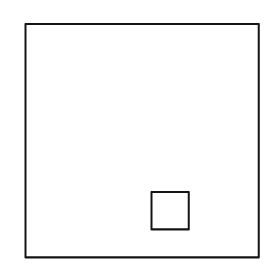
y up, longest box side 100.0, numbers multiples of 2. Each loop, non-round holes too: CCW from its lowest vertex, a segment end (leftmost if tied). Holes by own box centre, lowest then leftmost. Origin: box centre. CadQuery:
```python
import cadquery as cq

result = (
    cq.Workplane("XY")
    .moveTo(-50.0, -50.0)
    .lineTo(50.0, -50.0)
    .lineTo(50.0, 50.0)
    .lineTo(-50.0, 50.0)
    .close()
    .moveTo(4.0, -38.0)
    .lineTo(20.0, -38.0)
    .lineTo(20.0, -22.0)
    .lineTo(4.0, -22.0)
    .close()
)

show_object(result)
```